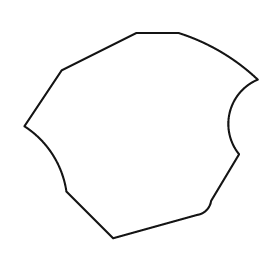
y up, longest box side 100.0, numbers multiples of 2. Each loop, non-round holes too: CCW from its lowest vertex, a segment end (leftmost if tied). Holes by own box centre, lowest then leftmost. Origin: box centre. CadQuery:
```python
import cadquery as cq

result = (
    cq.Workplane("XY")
    .moveTo(-12.0, -44.0)
    .lineTo(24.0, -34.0)
    .threePointArc((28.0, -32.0), (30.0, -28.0))
    .lineTo(42.0, -8.0)
    .threePointArc((38.0, 10.0), (50.0, 24.0))
    .threePointArc((34.0, 36.0), (16.0, 44.0))
    .lineTo(-2.0, 44.0)
    .lineTo(-34.0, 28.0)
    .lineTo(-50.0, 4.0)
    .threePointArc((-38.0, -8.0), (-32.0, -24.0))
    .close()
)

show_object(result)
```